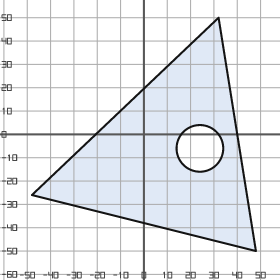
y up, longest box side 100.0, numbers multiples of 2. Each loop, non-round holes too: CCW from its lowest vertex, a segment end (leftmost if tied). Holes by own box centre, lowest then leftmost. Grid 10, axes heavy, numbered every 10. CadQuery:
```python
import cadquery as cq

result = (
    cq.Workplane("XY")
    .moveTo(48.0, -50.0)
    .lineTo(32.0, 50.0)
    .lineTo(-48.0, -26.0)
    .close()
    .moveTo(24.0, -6.0)
    .circle(10.0)
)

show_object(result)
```